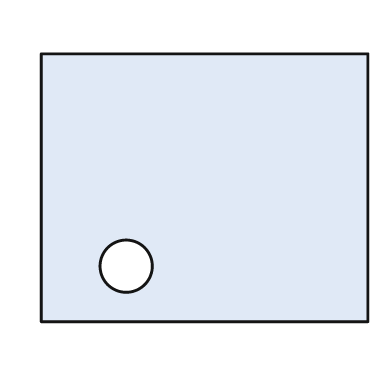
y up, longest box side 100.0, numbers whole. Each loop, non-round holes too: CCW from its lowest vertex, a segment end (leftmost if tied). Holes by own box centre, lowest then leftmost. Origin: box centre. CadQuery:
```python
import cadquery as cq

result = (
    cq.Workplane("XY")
    .moveTo(-50.0, -41.0)
    .lineTo(50.0, -41.0)
    .lineTo(50.0, 41.0)
    .lineTo(-50.0, 41.0)
    .close()
    .moveTo(-24.0, -24.0)
    .circle(8.0)
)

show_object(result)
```